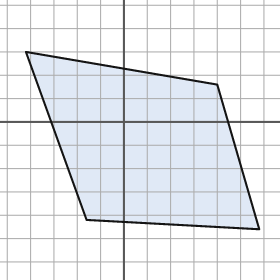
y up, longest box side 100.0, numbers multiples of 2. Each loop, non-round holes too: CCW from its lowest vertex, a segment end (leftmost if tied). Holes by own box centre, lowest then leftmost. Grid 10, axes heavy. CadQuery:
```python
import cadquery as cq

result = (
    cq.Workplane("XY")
    .moveTo(58.0, -46.0)
    .lineTo(40.0, 16.0)
    .lineTo(-42.0, 30.0)
    .lineTo(-16.0, -42.0)
    .close()
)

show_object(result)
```